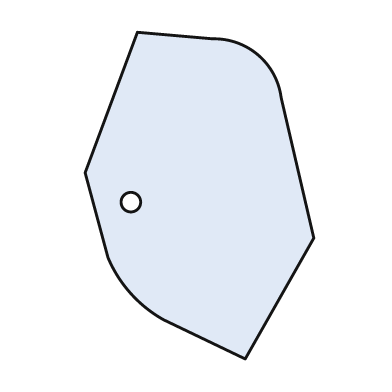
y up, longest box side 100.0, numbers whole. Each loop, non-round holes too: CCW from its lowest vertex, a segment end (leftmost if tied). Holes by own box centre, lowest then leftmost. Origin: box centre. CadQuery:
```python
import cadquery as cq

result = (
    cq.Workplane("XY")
    .moveTo(14.0, -50.0)
    .lineTo(35.0, -13.0)
    .lineTo(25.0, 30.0)
    .threePointArc((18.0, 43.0), (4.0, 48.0))
    .lineTo(-19.0, 50.0)
    .lineTo(-35.0, 7.0)
    .lineTo(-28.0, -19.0)
    .threePointArc((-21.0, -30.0), (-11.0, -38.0))
    .close()
    .moveTo(-21.0, -2.0)
    .circle(3.0)
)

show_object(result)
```